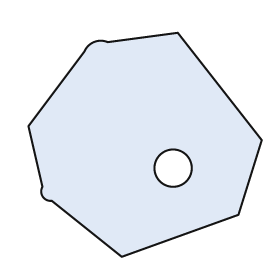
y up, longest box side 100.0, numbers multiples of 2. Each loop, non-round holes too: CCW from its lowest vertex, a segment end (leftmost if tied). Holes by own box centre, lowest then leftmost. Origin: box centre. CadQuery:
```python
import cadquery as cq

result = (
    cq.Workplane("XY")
    .moveTo(-10.0, -48.0)
    .lineTo(40.0, -30.0)
    .lineTo(50.0, 2.0)
    .lineTo(14.0, 48.0)
    .lineTo(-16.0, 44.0)
    .threePointArc((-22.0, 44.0), (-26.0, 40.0))
    .lineTo(-50.0, 8.0)
    .lineTo(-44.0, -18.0)
    .threePointArc((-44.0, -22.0), (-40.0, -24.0))
    .close()
    .moveTo(12.0, -10.0)
    .circle(8.0)
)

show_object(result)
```